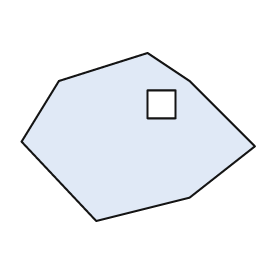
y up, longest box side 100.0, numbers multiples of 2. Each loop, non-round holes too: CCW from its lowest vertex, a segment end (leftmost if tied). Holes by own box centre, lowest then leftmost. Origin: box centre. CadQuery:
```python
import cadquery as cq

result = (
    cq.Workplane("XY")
    .moveTo(-18.0, -36.0)
    .lineTo(22.0, -26.0)
    .lineTo(50.0, -4.0)
    .lineTo(22.0, 24.0)
    .lineTo(4.0, 36.0)
    .lineTo(-34.0, 24.0)
    .lineTo(-50.0, -2.0)
    .close()
    .moveTo(4.0, 8.0)
    .lineTo(16.0, 8.0)
    .lineTo(16.0, 20.0)
    .lineTo(4.0, 20.0)
    .close()
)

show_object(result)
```